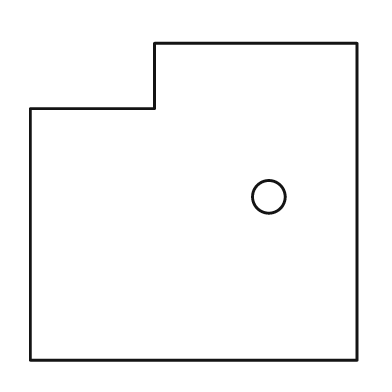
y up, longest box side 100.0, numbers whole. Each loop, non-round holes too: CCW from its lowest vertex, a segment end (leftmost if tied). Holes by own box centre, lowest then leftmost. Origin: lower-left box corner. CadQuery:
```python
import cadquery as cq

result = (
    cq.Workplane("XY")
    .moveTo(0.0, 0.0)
    .lineTo(100.0, 0.0)
    .lineTo(100.0, 97.0)
    .lineTo(38.0, 97.0)
    .lineTo(38.0, 77.0)
    .lineTo(0.0, 77.0)
    .close()
    .moveTo(73.0, 50.0)
    .circle(5.0)
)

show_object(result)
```